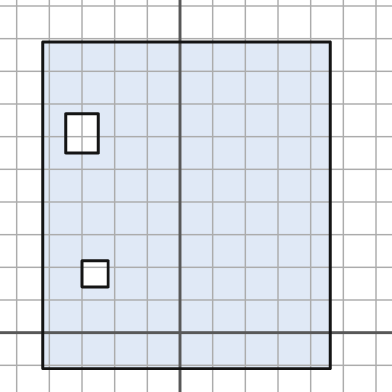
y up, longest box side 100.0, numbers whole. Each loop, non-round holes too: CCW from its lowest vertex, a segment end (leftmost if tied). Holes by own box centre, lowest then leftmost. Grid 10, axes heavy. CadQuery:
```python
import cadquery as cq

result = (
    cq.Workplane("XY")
    .moveTo(-42.0, -11.0)
    .lineTo(46.0, -11.0)
    .lineTo(46.0, 89.0)
    .lineTo(-42.0, 89.0)
    .close()
    .moveTo(-30.0, 14.0)
    .lineTo(-22.0, 14.0)
    .lineTo(-22.0, 22.0)
    .lineTo(-30.0, 22.0)
    .close()
    .moveTo(-35.0, 55.0)
    .lineTo(-25.0, 55.0)
    .lineTo(-25.0, 67.0)
    .lineTo(-35.0, 67.0)
    .close()
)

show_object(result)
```